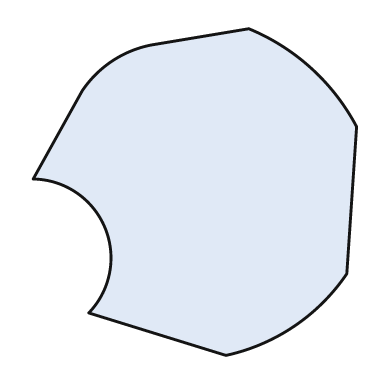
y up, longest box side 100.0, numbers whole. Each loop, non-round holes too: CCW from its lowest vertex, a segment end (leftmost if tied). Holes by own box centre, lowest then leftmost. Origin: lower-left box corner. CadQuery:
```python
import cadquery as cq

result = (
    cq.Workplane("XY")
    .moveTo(59.0, 0.0)
    .threePointArc((80.0, 9.0), (96.0, 25.0))
    .lineTo(99.0, 70.0)
    .threePointArc((85.0, 88.0), (66.0, 100.0))
    .lineTo(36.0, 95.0)
    .threePointArc((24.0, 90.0), (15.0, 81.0))
    .lineTo(0.0, 54.0)
    .threePointArc((22.0, 39.0), (17.0, 13.0))
    .close()
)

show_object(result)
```